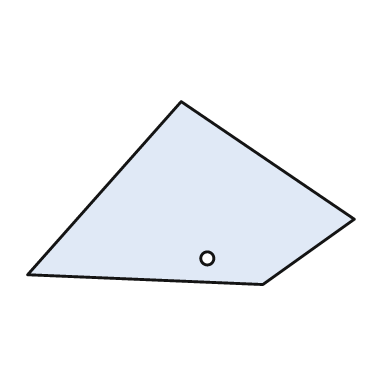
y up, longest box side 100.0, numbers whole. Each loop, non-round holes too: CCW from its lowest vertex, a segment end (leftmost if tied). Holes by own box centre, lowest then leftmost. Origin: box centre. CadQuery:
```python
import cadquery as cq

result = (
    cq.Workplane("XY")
    .moveTo(22.0, -28.0)
    .lineTo(50.0, -8.0)
    .lineTo(-3.0, 28.0)
    .lineTo(-50.0, -25.0)
    .close()
    .moveTo(5.0, -20.0)
    .circle(2.0)
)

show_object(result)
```